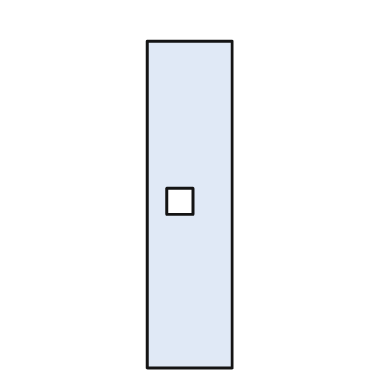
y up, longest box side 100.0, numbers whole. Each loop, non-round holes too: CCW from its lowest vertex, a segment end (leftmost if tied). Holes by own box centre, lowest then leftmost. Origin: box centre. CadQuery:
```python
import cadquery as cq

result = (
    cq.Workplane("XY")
    .moveTo(-13.0, -50.0)
    .lineTo(13.0, -50.0)
    .lineTo(13.0, 50.0)
    .lineTo(-13.0, 50.0)
    .close()
    .moveTo(-7.0, -3.0)
    .lineTo(1.0, -3.0)
    .lineTo(1.0, 5.0)
    .lineTo(-7.0, 5.0)
    .close()
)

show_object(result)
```